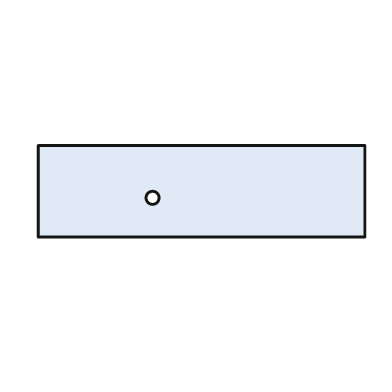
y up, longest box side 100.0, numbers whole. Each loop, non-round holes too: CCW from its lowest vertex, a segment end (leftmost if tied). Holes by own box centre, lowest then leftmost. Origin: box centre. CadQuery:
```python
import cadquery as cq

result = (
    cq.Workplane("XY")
    .moveTo(-50.0, -14.0)
    .lineTo(50.0, -14.0)
    .lineTo(50.0, 14.0)
    .lineTo(-50.0, 14.0)
    .close()
    .moveTo(-15.0, -2.0)
    .circle(2.0)
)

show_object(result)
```